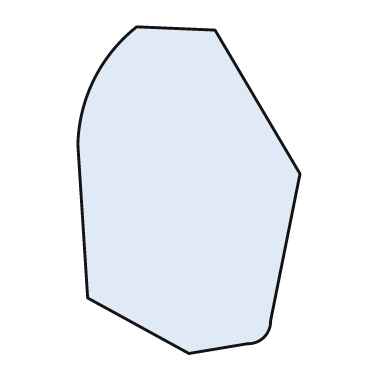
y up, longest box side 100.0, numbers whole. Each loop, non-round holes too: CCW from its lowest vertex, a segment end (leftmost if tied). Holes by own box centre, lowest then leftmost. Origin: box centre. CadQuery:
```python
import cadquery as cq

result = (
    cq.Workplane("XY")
    .moveTo(0.0, -50.0)
    .lineTo(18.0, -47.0)
    .threePointArc((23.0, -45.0), (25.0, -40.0))
    .lineTo(34.0, 5.0)
    .lineTo(8.0, 49.0)
    .lineTo(-16.0, 50.0)
    .threePointArc((-29.0, 34.0), (-34.0, 14.0))
    .lineTo(-31.0, -33.0)
    .close()
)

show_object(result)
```